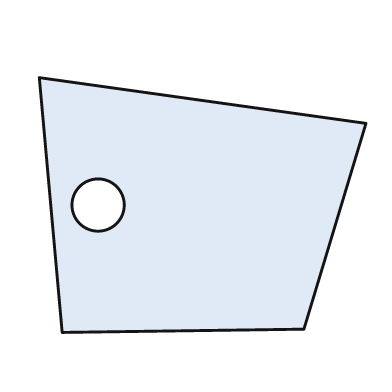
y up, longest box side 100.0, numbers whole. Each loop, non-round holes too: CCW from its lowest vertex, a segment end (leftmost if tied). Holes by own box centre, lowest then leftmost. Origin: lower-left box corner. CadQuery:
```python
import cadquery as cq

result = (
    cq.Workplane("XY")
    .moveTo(7.0, 0.0)
    .lineTo(81.0, 1.0)
    .lineTo(100.0, 64.0)
    .lineTo(0.0, 78.0)
    .close()
    .moveTo(18.0, 39.0)
    .circle(8.0)
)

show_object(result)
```